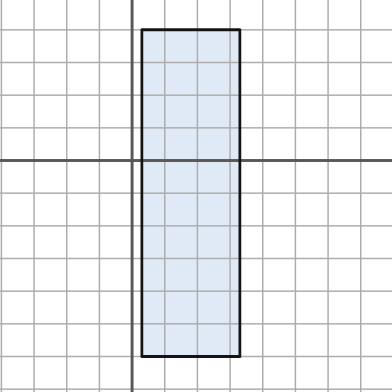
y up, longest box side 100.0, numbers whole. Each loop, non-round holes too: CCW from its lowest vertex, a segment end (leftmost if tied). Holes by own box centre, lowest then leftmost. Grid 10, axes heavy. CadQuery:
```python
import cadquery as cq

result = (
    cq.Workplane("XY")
    .moveTo(3.0, -60.0)
    .lineTo(33.0, -60.0)
    .lineTo(33.0, 40.0)
    .lineTo(3.0, 40.0)
    .close()
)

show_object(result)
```